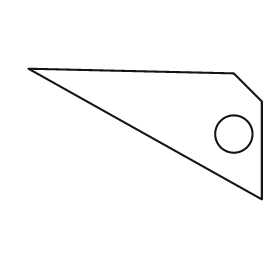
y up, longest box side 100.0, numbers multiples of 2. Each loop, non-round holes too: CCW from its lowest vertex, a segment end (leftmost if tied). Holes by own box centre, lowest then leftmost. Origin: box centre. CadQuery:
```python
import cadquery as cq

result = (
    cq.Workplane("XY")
    .moveTo(50.0, -28.0)
    .lineTo(50.0, 14.0)
    .lineTo(38.0, 26.0)
    .lineTo(-50.0, 28.0)
    .close()
    .moveTo(38.0, 0.0)
    .circle(8.0)
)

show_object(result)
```